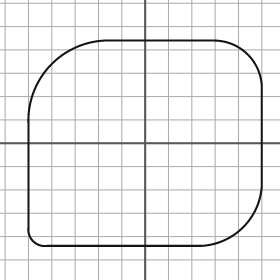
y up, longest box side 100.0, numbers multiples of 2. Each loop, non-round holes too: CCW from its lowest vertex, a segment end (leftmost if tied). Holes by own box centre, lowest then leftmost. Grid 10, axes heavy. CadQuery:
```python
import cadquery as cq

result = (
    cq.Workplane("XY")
    .moveTo(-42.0, -44.0)
    .lineTo(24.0, -44.0)
    .threePointArc((42.0, -36.0), (50.0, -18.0))
    .lineTo(50.0, 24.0)
    .threePointArc((44.0, 38.0), (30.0, 44.0))
    .lineTo(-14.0, 44.0)
    .threePointArc((-40.0, 34.0), (-50.0, 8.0))
    .lineTo(-50.0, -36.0)
    .threePointArc((-48.0, -42.0), (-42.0, -44.0))
    .close()
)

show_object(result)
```